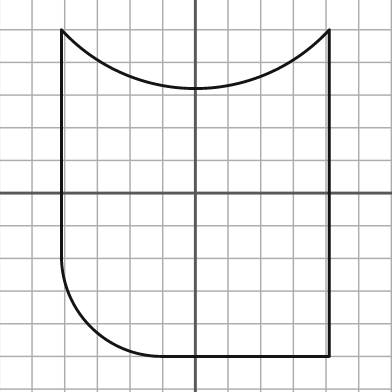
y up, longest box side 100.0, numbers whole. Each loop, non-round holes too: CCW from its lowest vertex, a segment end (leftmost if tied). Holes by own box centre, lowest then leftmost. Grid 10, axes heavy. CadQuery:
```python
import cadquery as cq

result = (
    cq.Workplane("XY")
    .moveTo(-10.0, -50.0)
    .lineTo(41.0, -50.0)
    .lineTo(41.0, 50.0)
    .threePointArc((0.0, 32.0), (-41.0, 50.0))
    .lineTo(-41.0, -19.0)
    .threePointArc((-32.0, -41.0), (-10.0, -50.0))
    .close()
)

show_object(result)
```